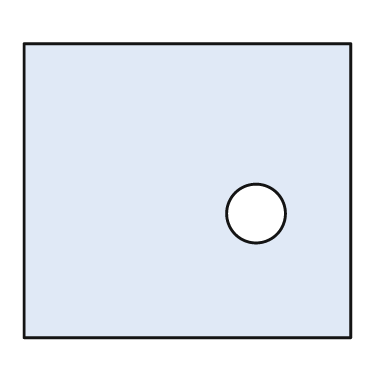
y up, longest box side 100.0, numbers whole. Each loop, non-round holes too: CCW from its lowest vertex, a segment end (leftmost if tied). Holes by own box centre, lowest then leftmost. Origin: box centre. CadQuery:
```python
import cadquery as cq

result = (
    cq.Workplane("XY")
    .moveTo(-50.0, -45.0)
    .lineTo(50.0, -45.0)
    .lineTo(50.0, 45.0)
    .lineTo(-50.0, 45.0)
    .close()
    .moveTo(21.0, -7.0)
    .circle(9.0)
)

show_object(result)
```